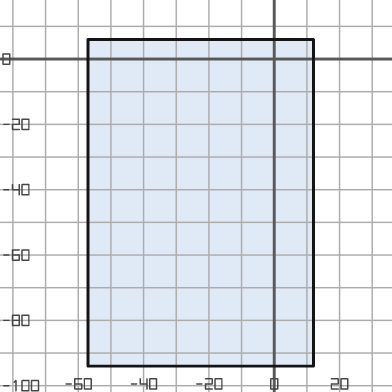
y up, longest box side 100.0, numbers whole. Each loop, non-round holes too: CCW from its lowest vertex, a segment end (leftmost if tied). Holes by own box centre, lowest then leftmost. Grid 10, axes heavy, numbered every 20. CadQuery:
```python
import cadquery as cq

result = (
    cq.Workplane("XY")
    .moveTo(-57.0, -94.0)
    .lineTo(12.0, -94.0)
    .lineTo(12.0, 6.0)
    .lineTo(-57.0, 6.0)
    .close()
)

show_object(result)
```